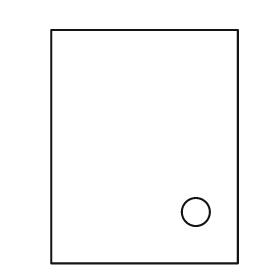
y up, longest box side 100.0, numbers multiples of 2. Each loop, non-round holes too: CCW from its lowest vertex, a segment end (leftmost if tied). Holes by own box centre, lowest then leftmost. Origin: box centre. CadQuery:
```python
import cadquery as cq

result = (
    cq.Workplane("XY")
    .moveTo(-40.0, -50.0)
    .lineTo(40.0, -50.0)
    .lineTo(40.0, 50.0)
    .lineTo(-40.0, 50.0)
    .close()
    .moveTo(22.0, -28.0)
    .circle(6.0)
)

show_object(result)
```